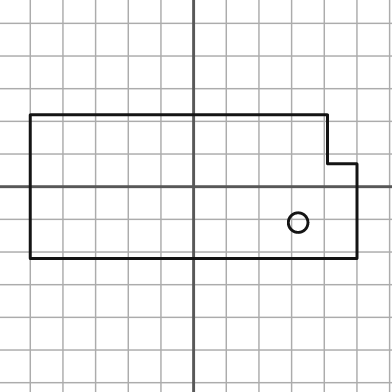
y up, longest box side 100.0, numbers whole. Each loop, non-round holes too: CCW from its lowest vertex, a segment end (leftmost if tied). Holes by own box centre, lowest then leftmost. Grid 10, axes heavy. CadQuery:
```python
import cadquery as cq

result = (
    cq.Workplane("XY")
    .moveTo(-50.0, -22.0)
    .lineTo(50.0, -22.0)
    .lineTo(50.0, 7.0)
    .lineTo(41.0, 7.0)
    .lineTo(41.0, 22.0)
    .lineTo(-50.0, 22.0)
    .close()
    .moveTo(32.0, -11.0)
    .circle(3.0)
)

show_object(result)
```